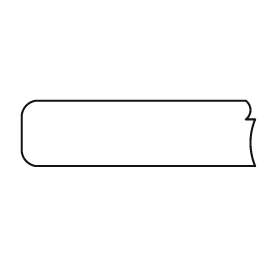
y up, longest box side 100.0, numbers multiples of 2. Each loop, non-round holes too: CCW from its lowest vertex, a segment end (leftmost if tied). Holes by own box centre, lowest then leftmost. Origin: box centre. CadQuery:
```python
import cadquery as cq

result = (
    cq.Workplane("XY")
    .moveTo(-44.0, -14.0)
    .lineTo(50.0, -14.0)
    .threePointArc((48.0, -4.0), (50.0, 6.0))
    .lineTo(46.0, 6.0)
    .threePointArc((48.0, 10.0), (46.0, 14.0))
    .lineTo(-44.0, 14.0)
    .threePointArc((-48.0, 12.0), (-50.0, 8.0))
    .lineTo(-50.0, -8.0)
    .threePointArc((-48.0, -12.0), (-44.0, -14.0))
    .close()
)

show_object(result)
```